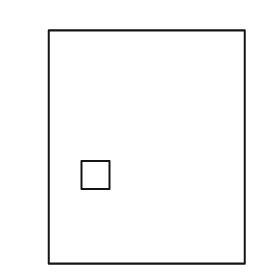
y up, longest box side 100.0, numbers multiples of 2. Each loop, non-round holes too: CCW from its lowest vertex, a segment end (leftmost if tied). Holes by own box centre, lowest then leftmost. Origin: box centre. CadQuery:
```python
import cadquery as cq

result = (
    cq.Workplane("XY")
    .moveTo(-42.0, -50.0)
    .lineTo(42.0, -50.0)
    .lineTo(42.0, 50.0)
    .lineTo(-42.0, 50.0)
    .close()
    .moveTo(-28.0, -18.0)
    .lineTo(-16.0, -18.0)
    .lineTo(-16.0, -6.0)
    .lineTo(-28.0, -6.0)
    .close()
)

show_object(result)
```